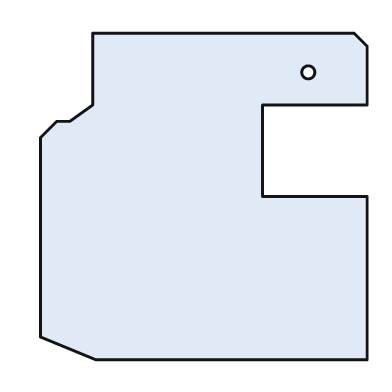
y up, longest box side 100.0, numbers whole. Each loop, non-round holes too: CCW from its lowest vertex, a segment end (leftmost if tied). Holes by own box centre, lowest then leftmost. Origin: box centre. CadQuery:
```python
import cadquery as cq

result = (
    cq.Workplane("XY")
    .moveTo(-33.0, -50.0)
    .lineTo(50.0, -50.0)
    .lineTo(50.0, 0.0)
    .lineTo(18.0, 0.0)
    .lineTo(18.0, 28.0)
    .lineTo(50.0, 28.0)
    .lineTo(50.0, 46.0)
    .lineTo(46.0, 50.0)
    .lineTo(-34.0, 50.0)
    .lineTo(-34.0, 28.0)
    .lineTo(-41.0, 23.0)
    .lineTo(-45.0, 23.0)
    .lineTo(-50.0, 18.0)
    .lineTo(-50.0, -43.0)
    .close()
    .moveTo(32.0, 38.0)
    .circle(2.0)
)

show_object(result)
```